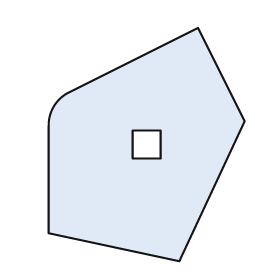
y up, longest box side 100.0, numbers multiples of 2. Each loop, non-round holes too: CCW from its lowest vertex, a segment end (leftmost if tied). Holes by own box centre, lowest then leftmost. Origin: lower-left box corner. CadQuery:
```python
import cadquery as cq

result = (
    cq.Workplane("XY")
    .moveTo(56.0, 0.0)
    .lineTo(84.0, 60.0)
    .lineTo(64.0, 100.0)
    .lineTo(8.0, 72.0)
    .threePointArc((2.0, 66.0), (0.0, 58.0))
    .lineTo(0.0, 12.0)
    .close()
    .moveTo(36.0, 44.0)
    .lineTo(48.0, 44.0)
    .lineTo(48.0, 56.0)
    .lineTo(36.0, 56.0)
    .close()
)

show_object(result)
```